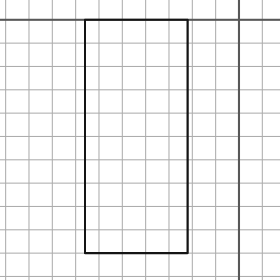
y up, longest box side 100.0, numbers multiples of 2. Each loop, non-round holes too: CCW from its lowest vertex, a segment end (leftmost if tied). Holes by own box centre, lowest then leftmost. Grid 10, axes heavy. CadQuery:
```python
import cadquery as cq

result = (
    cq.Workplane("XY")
    .moveTo(-66.0, -100.0)
    .lineTo(-22.0, -100.0)
    .lineTo(-22.0, 0.0)
    .lineTo(-66.0, 0.0)
    .close()
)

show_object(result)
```